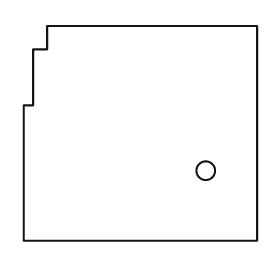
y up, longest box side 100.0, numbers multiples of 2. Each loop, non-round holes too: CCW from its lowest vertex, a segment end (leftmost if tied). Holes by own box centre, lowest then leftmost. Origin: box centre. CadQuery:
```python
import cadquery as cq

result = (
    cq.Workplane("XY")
    .moveTo(-50.0, -46.0)
    .lineTo(50.0, -46.0)
    .lineTo(50.0, 46.0)
    .lineTo(-40.0, 46.0)
    .lineTo(-40.0, 36.0)
    .lineTo(-46.0, 36.0)
    .lineTo(-46.0, 12.0)
    .lineTo(-50.0, 12.0)
    .close()
    .moveTo(28.0, -16.0)
    .circle(4.0)
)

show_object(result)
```